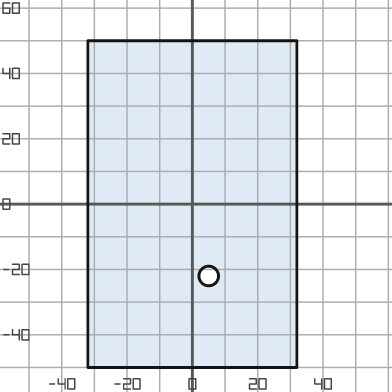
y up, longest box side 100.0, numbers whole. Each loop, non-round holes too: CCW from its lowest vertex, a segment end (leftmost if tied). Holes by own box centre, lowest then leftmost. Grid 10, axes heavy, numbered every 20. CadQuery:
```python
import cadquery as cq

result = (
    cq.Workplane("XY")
    .moveTo(-32.0, -50.0)
    .lineTo(32.0, -50.0)
    .lineTo(32.0, 50.0)
    .lineTo(-32.0, 50.0)
    .close()
    .moveTo(5.0, -22.0)
    .circle(3.0)
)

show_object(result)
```